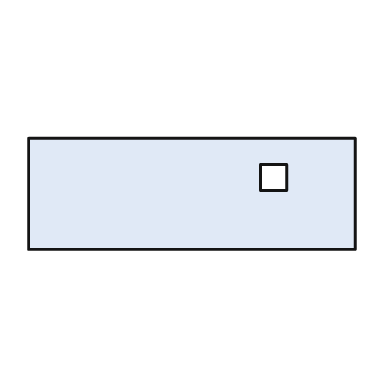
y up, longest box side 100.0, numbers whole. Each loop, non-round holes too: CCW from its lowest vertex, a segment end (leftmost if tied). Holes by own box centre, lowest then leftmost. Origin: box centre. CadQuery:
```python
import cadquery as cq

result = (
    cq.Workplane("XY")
    .moveTo(-50.0, -17.0)
    .lineTo(50.0, -17.0)
    .lineTo(50.0, 17.0)
    .lineTo(-50.0, 17.0)
    .close()
    .moveTo(21.0, 1.0)
    .lineTo(29.0, 1.0)
    .lineTo(29.0, 9.0)
    .lineTo(21.0, 9.0)
    .close()
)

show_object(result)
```